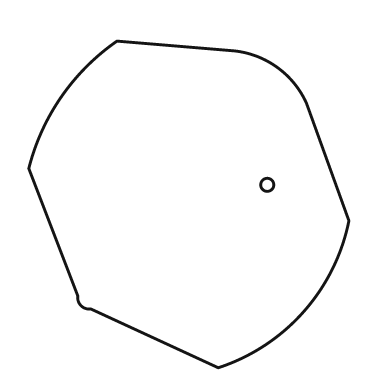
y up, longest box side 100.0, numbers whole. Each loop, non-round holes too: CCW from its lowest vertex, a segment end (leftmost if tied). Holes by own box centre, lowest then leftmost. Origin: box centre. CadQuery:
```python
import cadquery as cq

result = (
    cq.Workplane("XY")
    .moveTo(9.0, -50.0)
    .threePointArc((35.0, -33.0), (49.0, -5.0))
    .lineTo(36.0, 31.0)
    .threePointArc((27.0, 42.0), (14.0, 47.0))
    .lineTo(-22.0, 50.0)
    .threePointArc((-39.0, 33.0), (-49.0, 11.0))
    .lineTo(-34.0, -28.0)
    .threePointArc((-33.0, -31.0), (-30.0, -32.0))
    .close()
    .moveTo(24.0, 6.0)
    .circle(2.0)
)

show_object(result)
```